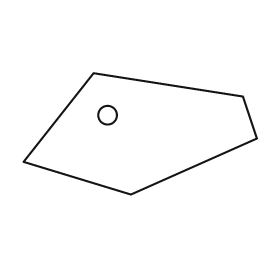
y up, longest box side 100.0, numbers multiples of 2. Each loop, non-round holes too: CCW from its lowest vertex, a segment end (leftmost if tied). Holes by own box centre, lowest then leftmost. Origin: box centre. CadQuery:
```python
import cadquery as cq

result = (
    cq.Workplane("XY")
    .moveTo(-4.0, -26.0)
    .lineTo(50.0, -2.0)
    .lineTo(44.0, 16.0)
    .lineTo(-20.0, 26.0)
    .lineTo(-50.0, -12.0)
    .close()
    .moveTo(-14.0, 8.0)
    .circle(4.0)
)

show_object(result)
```